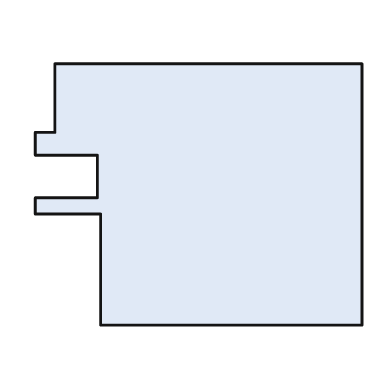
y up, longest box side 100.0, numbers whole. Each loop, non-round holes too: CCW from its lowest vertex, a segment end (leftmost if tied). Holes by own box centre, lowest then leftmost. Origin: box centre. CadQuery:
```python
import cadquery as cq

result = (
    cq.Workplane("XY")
    .moveTo(-30.0, -40.0)
    .lineTo(50.0, -40.0)
    .lineTo(50.0, 40.0)
    .lineTo(-44.0, 40.0)
    .lineTo(-44.0, 19.0)
    .lineTo(-50.0, 19.0)
    .lineTo(-50.0, 12.0)
    .lineTo(-31.0, 12.0)
    .lineTo(-31.0, -1.0)
    .lineTo(-50.0, -1.0)
    .lineTo(-50.0, -6.0)
    .lineTo(-30.0, -6.0)
    .close()
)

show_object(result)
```